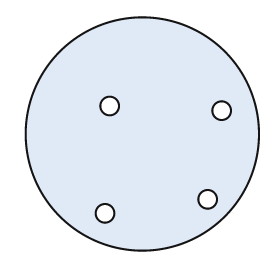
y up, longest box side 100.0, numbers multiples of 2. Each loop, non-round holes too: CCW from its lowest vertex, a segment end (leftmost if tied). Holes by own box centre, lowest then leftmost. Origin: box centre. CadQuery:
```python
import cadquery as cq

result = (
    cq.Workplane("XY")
    .moveTo(0.0, 0.0)
    .circle(50.0)
    .moveTo(-16.0, -34.0)
    .circle(4.0)
    .moveTo(28.0, -28.0)
    .circle(4.0)
    .moveTo(34.0, 10.0)
    .circle(4.0)
    .moveTo(-14.0, 12.0)
    .circle(4.0)
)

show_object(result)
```